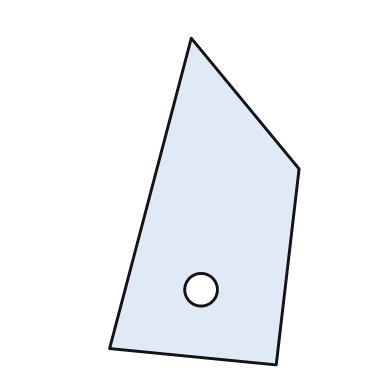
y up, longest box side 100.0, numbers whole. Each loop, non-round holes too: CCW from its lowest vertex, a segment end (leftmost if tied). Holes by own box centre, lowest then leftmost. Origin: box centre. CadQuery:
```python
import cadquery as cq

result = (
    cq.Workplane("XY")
    .moveTo(22.0, -50.0)
    .lineTo(29.0, 10.0)
    .lineTo(-4.0, 50.0)
    .lineTo(-29.0, -45.0)
    .close()
    .moveTo(-1.0, -27.0)
    .circle(5.0)
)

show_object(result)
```